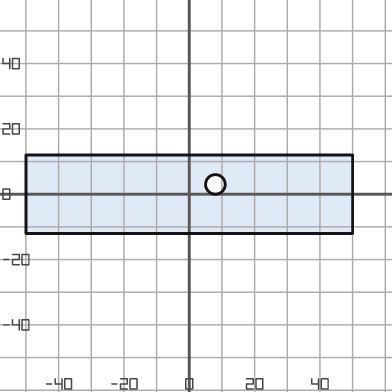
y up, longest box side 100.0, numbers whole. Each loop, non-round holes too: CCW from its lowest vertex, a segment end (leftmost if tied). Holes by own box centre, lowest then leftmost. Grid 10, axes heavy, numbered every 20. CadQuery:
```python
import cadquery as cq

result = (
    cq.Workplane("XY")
    .moveTo(-50.0, -12.0)
    .lineTo(50.0, -12.0)
    .lineTo(50.0, 12.0)
    .lineTo(-50.0, 12.0)
    .close()
    .moveTo(8.0, 3.0)
    .circle(3.0)
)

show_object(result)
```